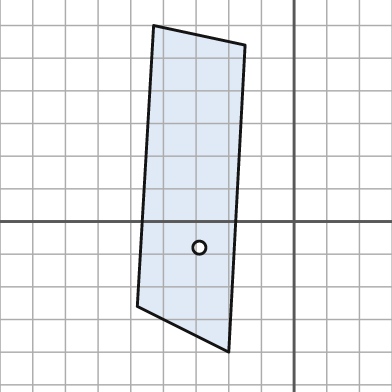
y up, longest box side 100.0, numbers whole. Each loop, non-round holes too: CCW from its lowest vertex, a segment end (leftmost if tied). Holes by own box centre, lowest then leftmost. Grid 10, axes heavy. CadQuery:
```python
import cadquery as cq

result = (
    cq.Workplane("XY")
    .moveTo(-20.0, -40.0)
    .lineTo(-15.0, 54.0)
    .lineTo(-43.0, 60.0)
    .lineTo(-48.0, -26.0)
    .close()
    .moveTo(-29.0, -8.0)
    .circle(2.0)
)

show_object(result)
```